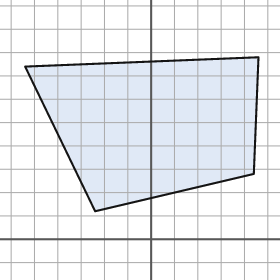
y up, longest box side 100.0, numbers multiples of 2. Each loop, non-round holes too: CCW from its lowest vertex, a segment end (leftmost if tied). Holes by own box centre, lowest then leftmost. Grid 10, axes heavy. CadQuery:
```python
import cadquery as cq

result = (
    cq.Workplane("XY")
    .moveTo(-24.0, 12.0)
    .lineTo(44.0, 28.0)
    .lineTo(46.0, 78.0)
    .lineTo(-54.0, 74.0)
    .close()
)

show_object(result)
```